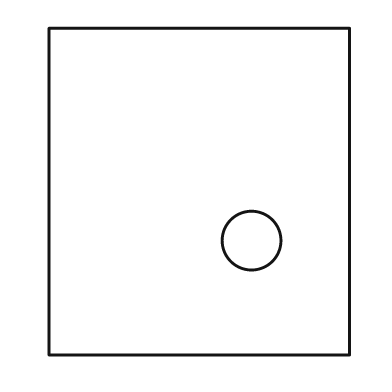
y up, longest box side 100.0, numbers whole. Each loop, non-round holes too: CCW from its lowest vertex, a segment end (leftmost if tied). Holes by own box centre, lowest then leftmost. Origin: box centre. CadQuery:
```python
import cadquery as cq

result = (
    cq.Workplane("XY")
    .moveTo(-46.0, -50.0)
    .lineTo(46.0, -50.0)
    .lineTo(46.0, 50.0)
    .lineTo(-46.0, 50.0)
    .close()
    .moveTo(16.0, -15.0)
    .circle(9.0)
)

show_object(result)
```